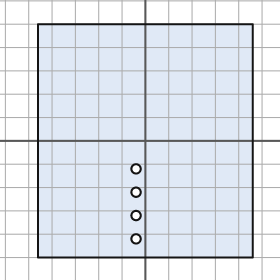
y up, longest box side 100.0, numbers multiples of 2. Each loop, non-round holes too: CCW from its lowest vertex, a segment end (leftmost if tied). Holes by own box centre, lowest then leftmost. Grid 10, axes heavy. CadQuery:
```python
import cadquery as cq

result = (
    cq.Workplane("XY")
    .moveTo(-46.0, -50.0)
    .lineTo(46.0, -50.0)
    .lineTo(46.0, 50.0)
    .lineTo(-46.0, 50.0)
    .close()
    .moveTo(-4.0, -42.0)
    .circle(2.0)
    .moveTo(-4.0, -32.0)
    .circle(2.0)
    .moveTo(-4.0, -22.0)
    .circle(2.0)
    .moveTo(-4.0, -12.0)
    .circle(2.0)
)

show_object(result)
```